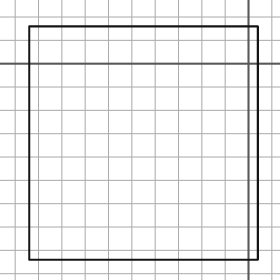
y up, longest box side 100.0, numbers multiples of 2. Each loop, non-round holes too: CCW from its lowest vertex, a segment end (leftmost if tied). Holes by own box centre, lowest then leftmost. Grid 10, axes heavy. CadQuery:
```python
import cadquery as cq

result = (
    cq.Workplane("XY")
    .moveTo(-94.0, -84.0)
    .lineTo(4.0, -84.0)
    .lineTo(4.0, 16.0)
    .lineTo(-94.0, 16.0)
    .close()
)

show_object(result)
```